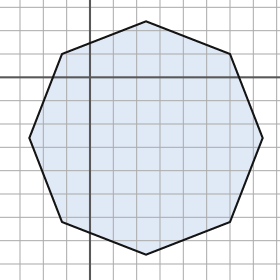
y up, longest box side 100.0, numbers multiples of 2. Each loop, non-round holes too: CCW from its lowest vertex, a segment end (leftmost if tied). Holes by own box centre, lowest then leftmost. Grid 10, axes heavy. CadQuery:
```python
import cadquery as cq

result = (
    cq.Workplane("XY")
    .moveTo(24.0, -76.0)
    .lineTo(60.0, -62.0)
    .lineTo(74.0, -26.0)
    .lineTo(60.0, 10.0)
    .lineTo(24.0, 24.0)
    .lineTo(-12.0, 10.0)
    .lineTo(-26.0, -26.0)
    .lineTo(-12.0, -62.0)
    .close()
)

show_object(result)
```